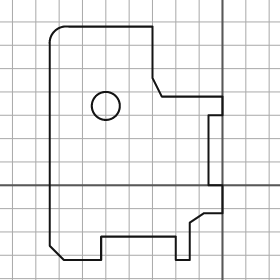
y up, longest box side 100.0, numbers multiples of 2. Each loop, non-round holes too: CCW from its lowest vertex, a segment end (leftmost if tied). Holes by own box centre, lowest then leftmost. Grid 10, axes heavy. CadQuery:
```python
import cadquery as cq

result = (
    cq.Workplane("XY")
    .moveTo(-68.0, -32.0)
    .lineTo(-52.0, -32.0)
    .lineTo(-52.0, -22.0)
    .lineTo(-20.0, -22.0)
    .lineTo(-20.0, -32.0)
    .lineTo(-14.0, -32.0)
    .lineTo(-14.0, -16.0)
    .lineTo(-8.0, -12.0)
    .lineTo(0.0, -12.0)
    .lineTo(0.0, 0.0)
    .lineTo(-6.0, 0.0)
    .lineTo(-6.0, 30.0)
    .lineTo(0.0, 30.0)
    .lineTo(0.0, 38.0)
    .lineTo(-26.0, 38.0)
    .lineTo(-30.0, 46.0)
    .lineTo(-30.0, 68.0)
    .lineTo(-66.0, 68.0)
    .threePointArc((-72.0, 66.0), (-74.0, 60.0))
    .lineTo(-74.0, -26.0)
    .close()
    .moveTo(-50.0, 34.0)
    .circle(6.0)
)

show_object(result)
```